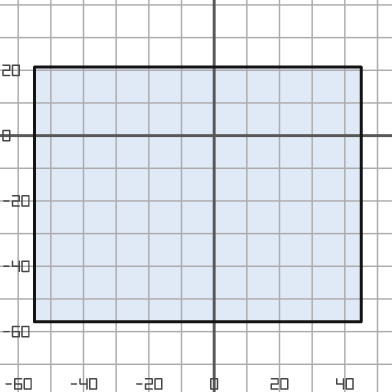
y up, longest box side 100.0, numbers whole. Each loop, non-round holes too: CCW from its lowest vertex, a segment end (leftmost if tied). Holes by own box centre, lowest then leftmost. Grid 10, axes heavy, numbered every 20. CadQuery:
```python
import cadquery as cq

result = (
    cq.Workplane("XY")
    .moveTo(-55.0, -57.0)
    .lineTo(45.0, -57.0)
    .lineTo(45.0, 21.0)
    .lineTo(-55.0, 21.0)
    .close()
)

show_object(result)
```